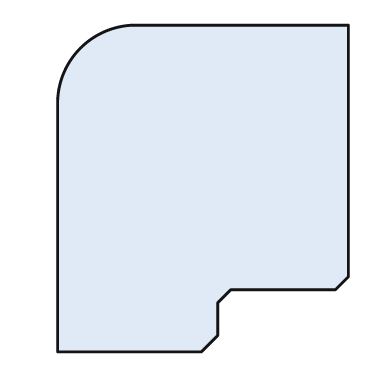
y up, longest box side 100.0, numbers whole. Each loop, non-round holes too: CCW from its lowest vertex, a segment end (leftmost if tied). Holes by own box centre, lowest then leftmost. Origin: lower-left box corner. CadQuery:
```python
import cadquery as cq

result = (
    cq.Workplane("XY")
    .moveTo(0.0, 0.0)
    .lineTo(44.0, 0.0)
    .lineTo(49.0, 5.0)
    .lineTo(49.0, 15.0)
    .lineTo(53.0, 19.0)
    .lineTo(85.0, 19.0)
    .lineTo(89.0, 23.0)
    .lineTo(89.0, 100.0)
    .lineTo(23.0, 100.0)
    .threePointArc((7.0, 93.0), (0.0, 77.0))
    .close()
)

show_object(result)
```